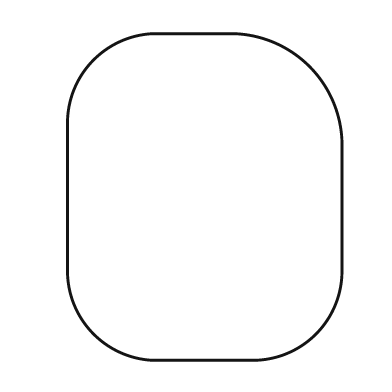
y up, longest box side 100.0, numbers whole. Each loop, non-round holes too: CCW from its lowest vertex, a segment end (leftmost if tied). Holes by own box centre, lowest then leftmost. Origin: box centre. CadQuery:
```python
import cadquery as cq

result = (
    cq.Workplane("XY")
    .moveTo(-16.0, -50.0)
    .lineTo(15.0, -50.0)
    .threePointArc((34.0, -42.0), (42.0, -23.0))
    .lineTo(42.0, 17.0)
    .threePointArc((32.0, 40.0), (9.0, 50.0))
    .lineTo(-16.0, 50.0)
    .threePointArc((-34.0, 42.0), (-42.0, 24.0))
    .lineTo(-42.0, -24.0)
    .threePointArc((-34.0, -42.0), (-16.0, -50.0))
    .close()
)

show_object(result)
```